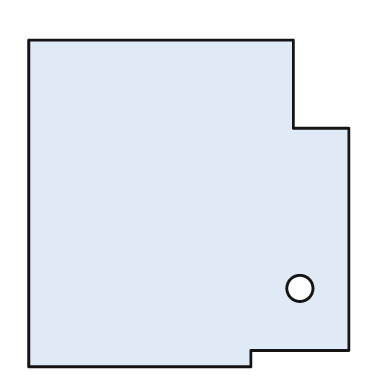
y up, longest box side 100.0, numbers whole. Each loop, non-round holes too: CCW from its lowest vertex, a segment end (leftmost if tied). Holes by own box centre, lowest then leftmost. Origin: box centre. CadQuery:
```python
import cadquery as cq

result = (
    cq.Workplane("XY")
    .moveTo(-49.0, -50.0)
    .lineTo(19.0, -50.0)
    .lineTo(19.0, -45.0)
    .lineTo(49.0, -45.0)
    .lineTo(49.0, 23.0)
    .lineTo(32.0, 23.0)
    .lineTo(32.0, 50.0)
    .lineTo(-49.0, 50.0)
    .close()
    .moveTo(34.0, -26.0)
    .circle(4.0)
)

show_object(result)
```